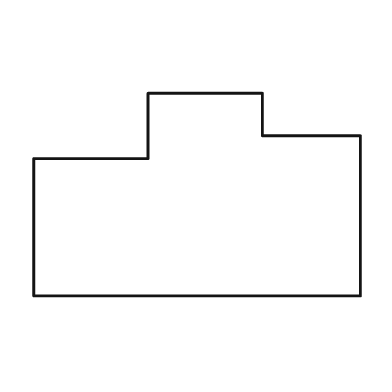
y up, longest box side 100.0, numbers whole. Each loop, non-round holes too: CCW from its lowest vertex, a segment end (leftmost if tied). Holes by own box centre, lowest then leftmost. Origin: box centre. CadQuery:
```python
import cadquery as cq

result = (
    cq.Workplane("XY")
    .moveTo(-50.0, -31.0)
    .lineTo(50.0, -31.0)
    .lineTo(50.0, 18.0)
    .lineTo(20.0, 18.0)
    .lineTo(20.0, 31.0)
    .lineTo(-15.0, 31.0)
    .lineTo(-15.0, 11.0)
    .lineTo(-50.0, 11.0)
    .close()
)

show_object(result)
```